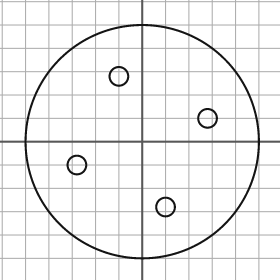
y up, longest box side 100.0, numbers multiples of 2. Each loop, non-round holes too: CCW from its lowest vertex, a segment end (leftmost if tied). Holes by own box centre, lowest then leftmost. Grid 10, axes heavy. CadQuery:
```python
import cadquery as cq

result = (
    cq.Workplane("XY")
    .moveTo(0.0, 0.0)
    .circle(50.0)
    .moveTo(10.0, -28.0)
    .circle(4.0)
    .moveTo(-28.0, -10.0)
    .circle(4.0)
    .moveTo(28.0, 10.0)
    .circle(4.0)
    .moveTo(-10.0, 28.0)
    .circle(4.0)
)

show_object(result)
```